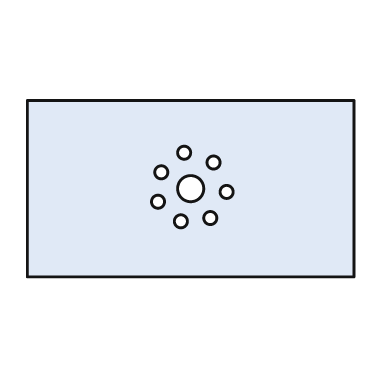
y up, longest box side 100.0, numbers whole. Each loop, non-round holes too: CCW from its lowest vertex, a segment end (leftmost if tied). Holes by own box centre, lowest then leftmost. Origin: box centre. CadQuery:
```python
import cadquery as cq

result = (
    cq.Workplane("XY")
    .moveTo(-50.0, -27.0)
    .lineTo(50.0, -27.0)
    .lineTo(50.0, 27.0)
    .lineTo(-50.0, 27.0)
    .close()
    .moveTo(-3.0, -10.0)
    .circle(2.0)
    .moveTo(6.0, -9.0)
    .circle(2.0)
    .moveTo(-10.0, -4.0)
    .circle(2.0)
    .moveTo(11.0, -1.0)
    .circle(2.0)
    .moveTo(0.0, 0.0)
    .circle(4.0)
    .moveTo(-9.0, 5.0)
    .circle(2.0)
    .moveTo(7.0, 8.0)
    .circle(2.0)
    .moveTo(-2.0, 11.0)
    .circle(2.0)
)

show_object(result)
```